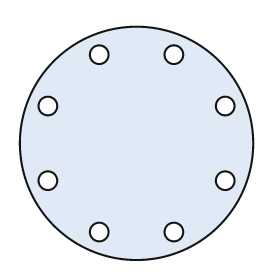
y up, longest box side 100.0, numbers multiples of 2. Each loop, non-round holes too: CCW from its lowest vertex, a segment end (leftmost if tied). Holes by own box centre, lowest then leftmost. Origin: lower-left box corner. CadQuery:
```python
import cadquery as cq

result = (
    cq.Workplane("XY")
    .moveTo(50.0, 50.0)
    .circle(50.0)
    .moveTo(34.0, 12.0)
    .circle(4.0)
    .moveTo(66.0, 12.0)
    .circle(4.0)
    .moveTo(12.0, 34.0)
    .circle(4.0)
    .moveTo(88.0, 34.0)
    .circle(4.0)
    .moveTo(12.0, 66.0)
    .circle(4.0)
    .moveTo(88.0, 66.0)
    .circle(4.0)
    .moveTo(34.0, 88.0)
    .circle(4.0)
    .moveTo(66.0, 88.0)
    .circle(4.0)
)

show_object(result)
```